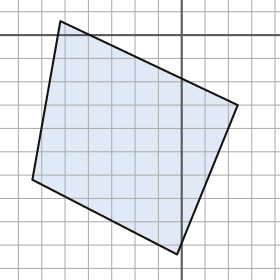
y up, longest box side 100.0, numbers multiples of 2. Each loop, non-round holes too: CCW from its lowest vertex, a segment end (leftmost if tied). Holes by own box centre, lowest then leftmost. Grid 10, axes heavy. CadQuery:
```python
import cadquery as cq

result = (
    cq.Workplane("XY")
    .moveTo(-2.0, -94.0)
    .lineTo(24.0, -30.0)
    .lineTo(-52.0, 6.0)
    .lineTo(-64.0, -62.0)
    .close()
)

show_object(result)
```